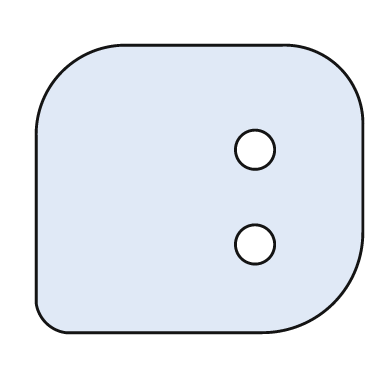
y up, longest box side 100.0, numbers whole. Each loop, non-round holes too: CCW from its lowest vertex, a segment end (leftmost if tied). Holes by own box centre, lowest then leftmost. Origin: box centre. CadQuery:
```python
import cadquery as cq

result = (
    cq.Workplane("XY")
    .moveTo(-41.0, -44.0)
    .lineTo(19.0, -44.0)
    .threePointArc((41.0, -35.0), (50.0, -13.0))
    .lineTo(50.0, 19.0)
    .threePointArc((43.0, 37.0), (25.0, 44.0))
    .lineTo(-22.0, 44.0)
    .threePointArc((-42.0, 36.0), (-50.0, 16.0))
    .lineTo(-50.0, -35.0)
    .threePointArc((-47.0, -41.0), (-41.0, -44.0))
    .close()
    .moveTo(17.0, -17.0)
    .circle(6.0)
    .moveTo(17.0, 12.0)
    .circle(6.0)
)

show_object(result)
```